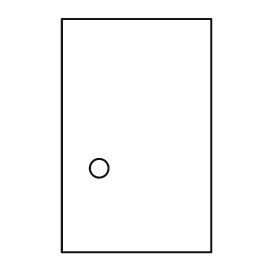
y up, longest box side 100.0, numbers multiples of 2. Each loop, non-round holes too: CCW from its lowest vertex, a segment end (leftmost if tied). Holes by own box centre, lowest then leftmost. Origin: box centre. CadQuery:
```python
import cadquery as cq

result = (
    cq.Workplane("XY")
    .moveTo(-32.0, -50.0)
    .lineTo(32.0, -50.0)
    .lineTo(32.0, 50.0)
    .lineTo(-32.0, 50.0)
    .close()
    .moveTo(-16.0, -14.0)
    .circle(4.0)
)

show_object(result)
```